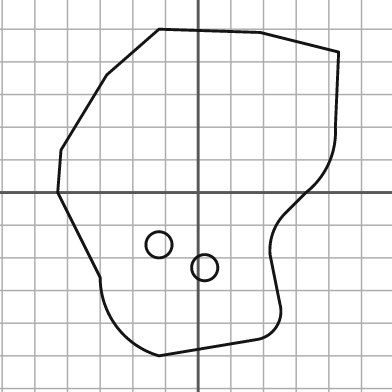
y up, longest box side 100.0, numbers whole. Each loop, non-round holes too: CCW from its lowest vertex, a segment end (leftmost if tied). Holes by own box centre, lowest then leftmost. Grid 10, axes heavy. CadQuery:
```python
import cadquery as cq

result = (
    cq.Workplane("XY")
    .moveTo(-12.0, -50.0)
    .lineTo(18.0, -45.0)
    .threePointArc((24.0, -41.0), (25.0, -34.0))
    .lineTo(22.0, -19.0)
    .threePointArc((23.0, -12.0), (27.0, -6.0))
    .lineTo(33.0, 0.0)
    .threePointArc((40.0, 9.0), (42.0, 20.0))
    .lineTo(43.0, 43.0)
    .lineTo(19.0, 49.0)
    .lineTo(-12.0, 50.0)
    .lineTo(-28.0, 36.0)
    .lineTo(-42.0, 13.0)
    .lineTo(-43.0, 0.0)
    .lineTo(-30.0, -26.0)
    .threePointArc((-25.0, -41.0), (-12.0, -50.0))
    .close()
    .moveTo(2.0, -23.0)
    .circle(4.0)
    .moveTo(-12.0, -16.0)
    .circle(4.0)
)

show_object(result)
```